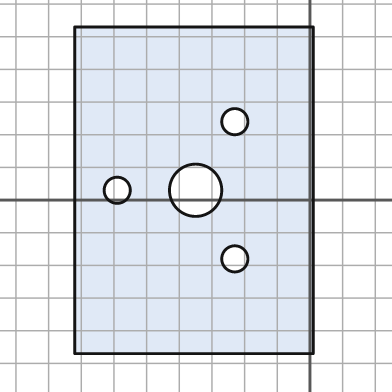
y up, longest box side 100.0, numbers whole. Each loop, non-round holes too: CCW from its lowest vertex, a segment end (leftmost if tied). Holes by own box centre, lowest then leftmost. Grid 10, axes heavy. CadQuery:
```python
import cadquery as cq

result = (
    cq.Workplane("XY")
    .moveTo(-72.0, -47.0)
    .lineTo(1.0, -47.0)
    .lineTo(1.0, 53.0)
    .lineTo(-72.0, 53.0)
    .close()
    .moveTo(-23.0, -18.0)
    .circle(4.0)
    .moveTo(-59.0, 3.0)
    .circle(4.0)
    .moveTo(-35.0, 3.0)
    .circle(8.0)
    .moveTo(-23.0, 24.0)
    .circle(4.0)
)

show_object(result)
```